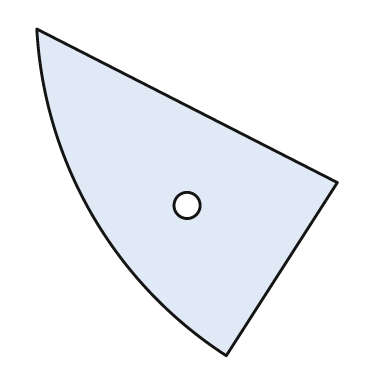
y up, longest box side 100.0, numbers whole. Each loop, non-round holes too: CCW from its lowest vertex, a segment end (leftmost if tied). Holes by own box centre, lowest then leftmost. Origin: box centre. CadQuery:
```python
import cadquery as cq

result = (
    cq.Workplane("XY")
    .moveTo(12.0, -50.0)
    .lineTo(46.0, 3.0)
    .lineTo(-46.0, 50.0)
    .threePointArc((-29.0, -7.0), (12.0, -50.0))
    .close()
    .moveTo(0.0, -4.0)
    .circle(4.0)
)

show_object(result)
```